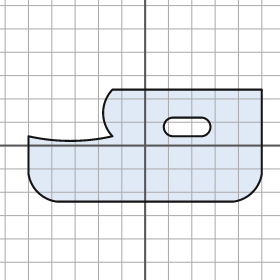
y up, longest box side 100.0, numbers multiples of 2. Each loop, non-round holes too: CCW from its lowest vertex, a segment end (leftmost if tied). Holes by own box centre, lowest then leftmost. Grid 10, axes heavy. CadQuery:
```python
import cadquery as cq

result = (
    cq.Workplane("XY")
    .moveTo(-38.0, -24.0)
    .lineTo(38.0, -24.0)
    .threePointArc((46.0, -20.0), (50.0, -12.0))
    .lineTo(50.0, 24.0)
    .lineTo(-14.0, 24.0)
    .threePointArc((-18.0, 14.0), (-14.0, 4.0))
    .threePointArc((-32.0, 2.0), (-50.0, 4.0))
    .lineTo(-50.0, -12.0)
    .threePointArc((-46.0, -20.0), (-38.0, -24.0))
    .close()
    .moveTo(12.0, 4.0)
    .lineTo(24.0, 4.0)
    .threePointArc((28.0, 8.0), (24.0, 12.0))
    .lineTo(12.0, 12.0)
    .threePointArc((8.0, 8.0), (12.0, 4.0))
    .close()
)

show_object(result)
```